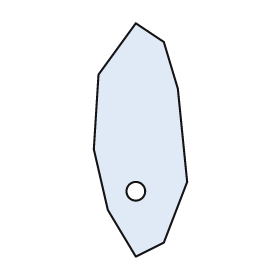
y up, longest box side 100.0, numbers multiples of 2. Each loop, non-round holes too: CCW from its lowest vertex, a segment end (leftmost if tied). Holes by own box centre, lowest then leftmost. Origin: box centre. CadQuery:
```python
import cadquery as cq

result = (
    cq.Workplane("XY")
    .moveTo(-2.0, -50.0)
    .lineTo(10.0, -44.0)
    .lineTo(20.0, -18.0)
    .lineTo(16.0, 22.0)
    .lineTo(10.0, 42.0)
    .lineTo(-2.0, 50.0)
    .lineTo(-18.0, 28.0)
    .lineTo(-20.0, -4.0)
    .lineTo(-14.0, -30.0)
    .close()
    .moveTo(-2.0, -22.0)
    .circle(4.0)
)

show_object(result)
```